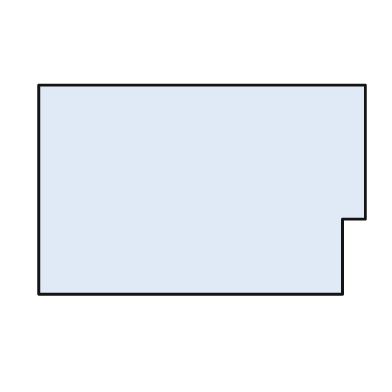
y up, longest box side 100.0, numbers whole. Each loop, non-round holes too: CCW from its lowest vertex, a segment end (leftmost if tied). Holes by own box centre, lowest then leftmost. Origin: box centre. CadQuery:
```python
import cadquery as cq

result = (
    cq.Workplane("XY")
    .moveTo(-50.0, -32.0)
    .lineTo(43.0, -32.0)
    .lineTo(43.0, -9.0)
    .lineTo(50.0, -9.0)
    .lineTo(50.0, 32.0)
    .lineTo(-50.0, 32.0)
    .close()
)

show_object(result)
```